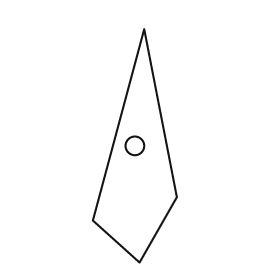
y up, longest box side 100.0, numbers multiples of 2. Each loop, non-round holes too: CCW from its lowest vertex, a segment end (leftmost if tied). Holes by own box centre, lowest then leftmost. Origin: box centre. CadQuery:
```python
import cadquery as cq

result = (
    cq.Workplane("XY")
    .moveTo(2.0, -50.0)
    .lineTo(18.0, -22.0)
    .lineTo(4.0, 50.0)
    .lineTo(-18.0, -32.0)
    .close()
    .moveTo(0.0, 0.0)
    .circle(4.0)
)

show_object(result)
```